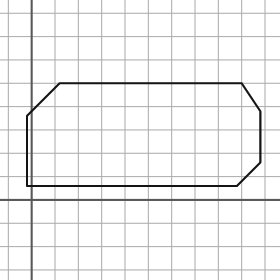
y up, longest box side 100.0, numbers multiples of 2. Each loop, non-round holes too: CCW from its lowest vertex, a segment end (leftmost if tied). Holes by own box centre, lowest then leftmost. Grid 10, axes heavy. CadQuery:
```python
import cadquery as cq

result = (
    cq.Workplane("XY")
    .moveTo(-2.0, 6.0)
    .lineTo(88.0, 6.0)
    .lineTo(98.0, 16.0)
    .lineTo(98.0, 38.0)
    .lineTo(90.0, 50.0)
    .lineTo(12.0, 50.0)
    .lineTo(-2.0, 36.0)
    .close()
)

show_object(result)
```